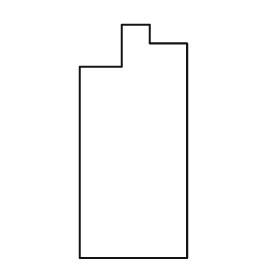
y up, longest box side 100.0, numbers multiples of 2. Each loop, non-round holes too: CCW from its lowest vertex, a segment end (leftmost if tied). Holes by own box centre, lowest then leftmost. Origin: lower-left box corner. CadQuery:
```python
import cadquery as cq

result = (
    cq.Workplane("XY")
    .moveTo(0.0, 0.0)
    .lineTo(46.0, 0.0)
    .lineTo(46.0, 92.0)
    .lineTo(30.0, 92.0)
    .lineTo(30.0, 100.0)
    .lineTo(18.0, 100.0)
    .lineTo(18.0, 82.0)
    .lineTo(0.0, 82.0)
    .close()
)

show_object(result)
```